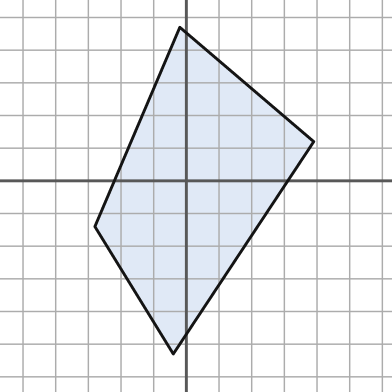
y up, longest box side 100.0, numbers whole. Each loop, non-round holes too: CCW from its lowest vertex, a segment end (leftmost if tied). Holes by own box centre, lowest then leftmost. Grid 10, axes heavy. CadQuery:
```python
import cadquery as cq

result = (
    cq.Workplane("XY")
    .moveTo(-4.0, -53.0)
    .lineTo(39.0, 12.0)
    .lineTo(-2.0, 47.0)
    .lineTo(-28.0, -14.0)
    .close()
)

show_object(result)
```